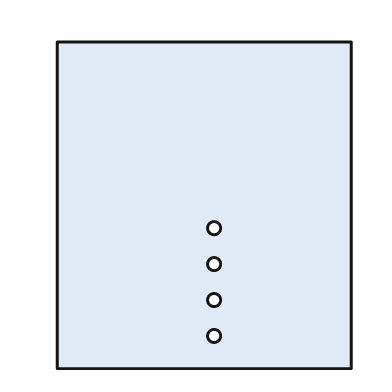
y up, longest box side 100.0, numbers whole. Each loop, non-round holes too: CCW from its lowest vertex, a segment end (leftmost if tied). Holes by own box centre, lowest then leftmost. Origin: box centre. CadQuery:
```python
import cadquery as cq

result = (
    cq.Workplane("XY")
    .moveTo(-45.0, -50.0)
    .lineTo(45.0, -50.0)
    .lineTo(45.0, 50.0)
    .lineTo(-45.0, 50.0)
    .close()
    .moveTo(3.0, -40.0)
    .circle(2.0)
    .moveTo(3.0, -29.0)
    .circle(2.0)
    .moveTo(3.0, -18.0)
    .circle(2.0)
    .moveTo(3.0, -7.0)
    .circle(2.0)
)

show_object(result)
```